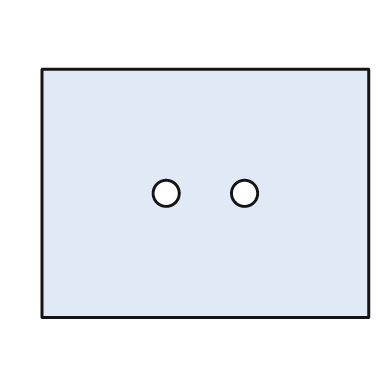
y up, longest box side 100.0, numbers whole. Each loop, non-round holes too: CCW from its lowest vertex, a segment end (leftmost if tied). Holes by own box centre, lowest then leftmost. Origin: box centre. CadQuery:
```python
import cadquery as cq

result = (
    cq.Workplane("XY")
    .moveTo(-50.0, -38.0)
    .lineTo(50.0, -38.0)
    .lineTo(50.0, 38.0)
    .lineTo(-50.0, 38.0)
    .close()
    .moveTo(-12.0, 0.0)
    .circle(4.0)
    .moveTo(12.0, 0.0)
    .circle(4.0)
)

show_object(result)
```